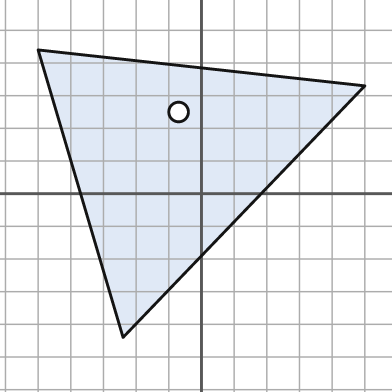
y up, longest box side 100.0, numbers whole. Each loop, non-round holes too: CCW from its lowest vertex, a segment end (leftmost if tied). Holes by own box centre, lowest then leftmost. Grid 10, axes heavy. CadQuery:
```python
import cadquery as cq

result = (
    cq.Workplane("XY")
    .moveTo(-24.0, -44.0)
    .lineTo(50.0, 33.0)
    .lineTo(-50.0, 44.0)
    .close()
    .moveTo(-7.0, 25.0)
    .circle(3.0)
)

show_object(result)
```